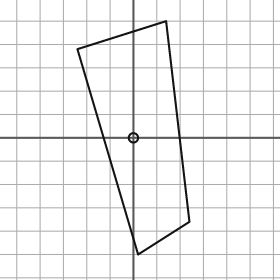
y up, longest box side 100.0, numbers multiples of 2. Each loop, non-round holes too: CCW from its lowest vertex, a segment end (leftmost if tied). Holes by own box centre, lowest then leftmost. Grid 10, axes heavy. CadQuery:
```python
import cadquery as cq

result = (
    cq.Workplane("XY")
    .moveTo(2.0, -50.0)
    .lineTo(24.0, -36.0)
    .lineTo(14.0, 50.0)
    .lineTo(-24.0, 38.0)
    .close()
    .moveTo(0.0, 0.0)
    .circle(2.0)
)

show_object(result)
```